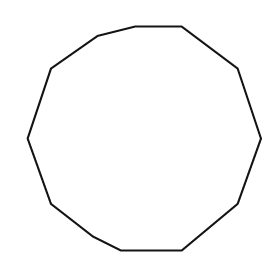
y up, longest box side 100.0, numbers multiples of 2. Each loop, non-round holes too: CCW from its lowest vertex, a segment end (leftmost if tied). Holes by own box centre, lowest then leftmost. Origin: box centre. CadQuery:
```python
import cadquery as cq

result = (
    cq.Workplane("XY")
    .moveTo(-10.0, -48.0)
    .lineTo(16.0, -48.0)
    .lineTo(40.0, -28.0)
    .lineTo(50.0, 0.0)
    .lineTo(40.0, 30.0)
    .lineTo(16.0, 48.0)
    .lineTo(-4.0, 48.0)
    .lineTo(-20.0, 44.0)
    .lineTo(-40.0, 30.0)
    .lineTo(-50.0, 0.0)
    .lineTo(-40.0, -28.0)
    .lineTo(-22.0, -42.0)
    .close()
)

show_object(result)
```